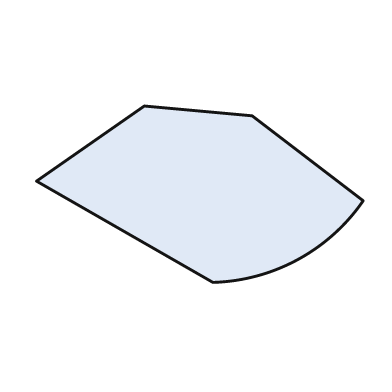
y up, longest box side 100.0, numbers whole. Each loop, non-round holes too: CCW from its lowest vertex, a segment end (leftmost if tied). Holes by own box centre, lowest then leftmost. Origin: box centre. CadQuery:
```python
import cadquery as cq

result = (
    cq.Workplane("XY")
    .moveTo(4.0, -27.0)
    .threePointArc((30.0, -20.0), (50.0, -2.0))
    .lineTo(16.0, 24.0)
    .lineTo(-17.0, 27.0)
    .lineTo(-50.0, 4.0)
    .close()
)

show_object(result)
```